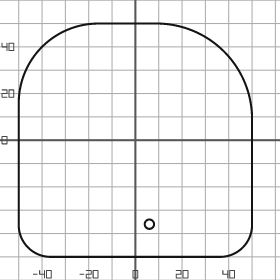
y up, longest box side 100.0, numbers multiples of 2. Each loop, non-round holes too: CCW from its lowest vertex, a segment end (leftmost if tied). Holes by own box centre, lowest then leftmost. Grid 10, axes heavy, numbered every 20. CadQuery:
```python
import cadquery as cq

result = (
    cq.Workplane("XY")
    .moveTo(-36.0, -50.0)
    .lineTo(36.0, -50.0)
    .threePointArc((46.0, -46.0), (50.0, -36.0))
    .lineTo(50.0, 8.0)
    .threePointArc((38.0, 38.0), (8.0, 50.0))
    .lineTo(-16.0, 50.0)
    .threePointArc((-40.0, 40.0), (-50.0, 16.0))
    .lineTo(-50.0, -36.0)
    .threePointArc((-46.0, -46.0), (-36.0, -50.0))
    .close()
    .moveTo(6.0, -36.0)
    .circle(2.0)
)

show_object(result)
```